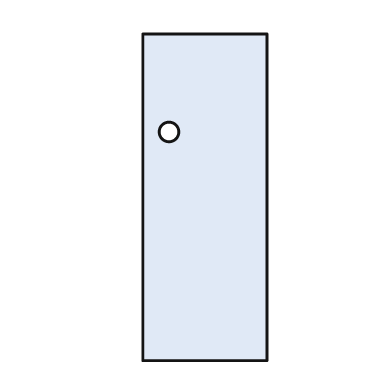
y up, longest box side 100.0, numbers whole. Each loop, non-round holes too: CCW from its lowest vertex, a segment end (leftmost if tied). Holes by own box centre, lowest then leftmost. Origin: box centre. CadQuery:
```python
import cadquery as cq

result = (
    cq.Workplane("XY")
    .moveTo(-19.0, -50.0)
    .lineTo(19.0, -50.0)
    .lineTo(19.0, 50.0)
    .lineTo(-19.0, 50.0)
    .close()
    .moveTo(-11.0, 20.0)
    .circle(3.0)
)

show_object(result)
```